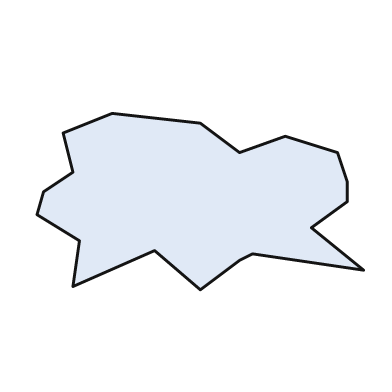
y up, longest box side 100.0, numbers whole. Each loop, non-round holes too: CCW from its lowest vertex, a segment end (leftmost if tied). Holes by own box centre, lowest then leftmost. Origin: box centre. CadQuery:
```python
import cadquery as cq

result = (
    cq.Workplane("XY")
    .moveTo(0.0, -27.0)
    .lineTo(12.0, -18.0)
    .lineTo(16.0, -16.0)
    .lineTo(50.0, -21.0)
    .lineTo(34.0, -8.0)
    .lineTo(45.0, 0.0)
    .lineTo(45.0, 6.0)
    .lineTo(42.0, 15.0)
    .lineTo(26.0, 20.0)
    .lineTo(12.0, 15.0)
    .lineTo(0.0, 24.0)
    .lineTo(-27.0, 27.0)
    .lineTo(-42.0, 21.0)
    .lineTo(-39.0, 9.0)
    .lineTo(-48.0, 3.0)
    .lineTo(-50.0, -4.0)
    .lineTo(-37.0, -12.0)
    .lineTo(-39.0, -26.0)
    .lineTo(-14.0, -15.0)
    .close()
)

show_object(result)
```